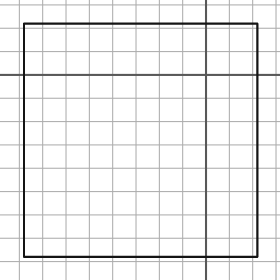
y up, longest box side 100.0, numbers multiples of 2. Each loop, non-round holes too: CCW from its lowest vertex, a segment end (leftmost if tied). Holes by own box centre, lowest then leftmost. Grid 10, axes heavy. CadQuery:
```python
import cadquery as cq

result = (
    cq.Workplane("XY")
    .moveTo(-78.0, -78.0)
    .lineTo(22.0, -78.0)
    .lineTo(22.0, 22.0)
    .lineTo(-78.0, 22.0)
    .close()
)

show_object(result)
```